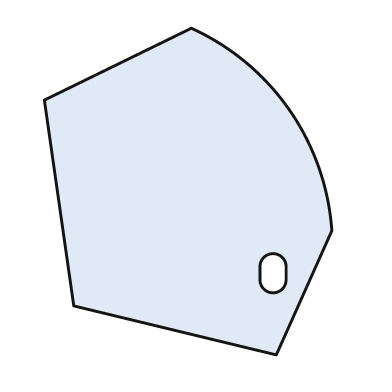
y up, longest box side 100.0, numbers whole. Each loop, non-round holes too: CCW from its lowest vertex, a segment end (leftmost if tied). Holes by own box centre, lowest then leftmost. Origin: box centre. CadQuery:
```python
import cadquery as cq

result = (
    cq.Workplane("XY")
    .moveTo(27.0, -50.0)
    .lineTo(44.0, -12.0)
    .threePointArc((31.0, 25.0), (1.0, 50.0))
    .lineTo(-44.0, 28.0)
    .lineTo(-35.0, -35.0)
    .close()
    .moveTo(22.0, -27.0)
    .threePointArc((26.0, -31.0), (30.0, -27.0))
    .lineTo(30.0, -23.0)
    .threePointArc((26.0, -19.0), (22.0, -23.0))
    .close()
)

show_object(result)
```